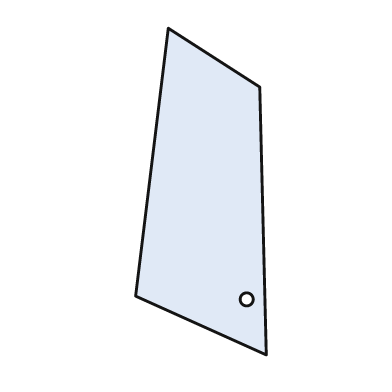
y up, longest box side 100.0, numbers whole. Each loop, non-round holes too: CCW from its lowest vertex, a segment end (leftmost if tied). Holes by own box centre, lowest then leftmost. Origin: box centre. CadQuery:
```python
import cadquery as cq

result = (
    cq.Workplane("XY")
    .moveTo(20.0, -50.0)
    .lineTo(18.0, 32.0)
    .lineTo(-10.0, 50.0)
    .lineTo(-20.0, -32.0)
    .close()
    .moveTo(14.0, -33.0)
    .circle(2.0)
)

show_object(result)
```